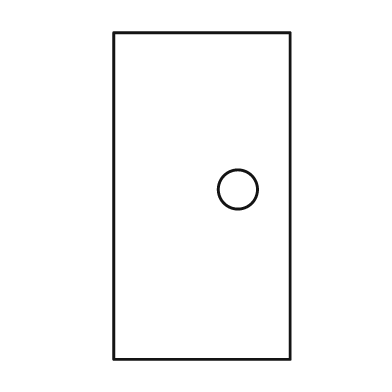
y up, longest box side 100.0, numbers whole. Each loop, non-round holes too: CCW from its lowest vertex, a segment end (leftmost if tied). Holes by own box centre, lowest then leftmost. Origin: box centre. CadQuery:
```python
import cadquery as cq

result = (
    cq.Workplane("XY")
    .moveTo(-27.0, -50.0)
    .lineTo(27.0, -50.0)
    .lineTo(27.0, 50.0)
    .lineTo(-27.0, 50.0)
    .close()
    .moveTo(11.0, 2.0)
    .circle(6.0)
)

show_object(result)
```